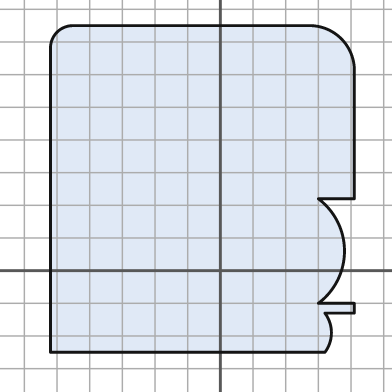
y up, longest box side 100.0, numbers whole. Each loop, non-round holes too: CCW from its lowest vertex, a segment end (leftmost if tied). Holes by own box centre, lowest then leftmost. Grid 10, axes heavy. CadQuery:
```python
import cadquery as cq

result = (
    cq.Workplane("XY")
    .moveTo(-52.0, -25.0)
    .lineTo(32.0, -25.0)
    .threePointArc((34.0, -19.0), (32.0, -13.0))
    .lineTo(41.0, -13.0)
    .lineTo(41.0, -10.0)
    .lineTo(30.0, -10.0)
    .threePointArc((38.0, 6.0), (30.0, 22.0))
    .lineTo(41.0, 22.0)
    .lineTo(41.0, 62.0)
    .threePointArc((37.0, 71.0), (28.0, 75.0))
    .lineTo(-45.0, 75.0)
    .threePointArc((-50.0, 73.0), (-52.0, 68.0))
    .close()
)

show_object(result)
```